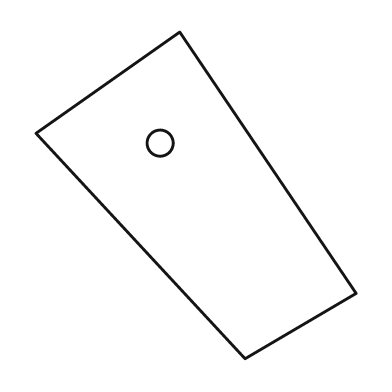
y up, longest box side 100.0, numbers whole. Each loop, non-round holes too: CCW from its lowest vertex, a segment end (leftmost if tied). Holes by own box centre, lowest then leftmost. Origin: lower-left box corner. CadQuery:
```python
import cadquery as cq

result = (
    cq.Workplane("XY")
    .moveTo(64.0, 0.0)
    .lineTo(98.0, 20.0)
    .lineTo(44.0, 100.0)
    .lineTo(0.0, 69.0)
    .close()
    .moveTo(38.0, 66.0)
    .circle(4.0)
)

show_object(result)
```